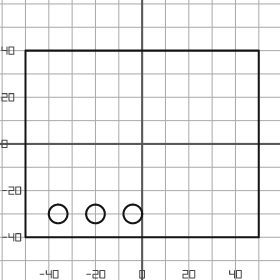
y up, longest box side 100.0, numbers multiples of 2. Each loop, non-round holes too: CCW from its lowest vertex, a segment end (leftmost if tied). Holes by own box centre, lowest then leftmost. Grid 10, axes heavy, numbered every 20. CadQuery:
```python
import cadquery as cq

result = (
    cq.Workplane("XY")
    .moveTo(-50.0, -40.0)
    .lineTo(50.0, -40.0)
    .lineTo(50.0, 40.0)
    .lineTo(-50.0, 40.0)
    .close()
    .moveTo(-36.0, -30.0)
    .circle(4.0)
    .moveTo(-20.0, -30.0)
    .circle(4.0)
    .moveTo(-4.0, -30.0)
    .circle(4.0)
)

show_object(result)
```